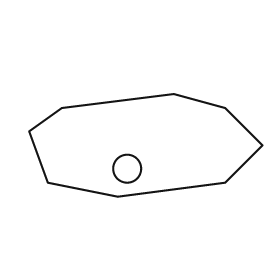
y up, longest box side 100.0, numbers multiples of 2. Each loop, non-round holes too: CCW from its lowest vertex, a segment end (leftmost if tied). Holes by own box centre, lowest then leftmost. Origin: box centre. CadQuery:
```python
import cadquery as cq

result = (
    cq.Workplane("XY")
    .moveTo(-12.0, -22.0)
    .lineTo(34.0, -16.0)
    .lineTo(50.0, 0.0)
    .lineTo(34.0, 16.0)
    .lineTo(12.0, 22.0)
    .lineTo(-36.0, 16.0)
    .lineTo(-50.0, 6.0)
    .lineTo(-42.0, -16.0)
    .close()
    .moveTo(-8.0, -10.0)
    .circle(6.0)
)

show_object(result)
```